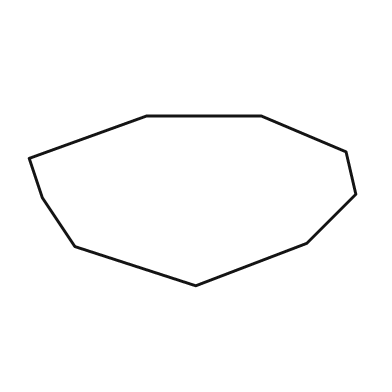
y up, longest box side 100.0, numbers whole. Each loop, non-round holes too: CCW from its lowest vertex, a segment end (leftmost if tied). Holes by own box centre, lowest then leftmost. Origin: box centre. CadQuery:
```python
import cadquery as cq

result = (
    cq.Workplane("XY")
    .moveTo(1.0, -26.0)
    .lineTo(35.0, -13.0)
    .lineTo(50.0, 2.0)
    .lineTo(47.0, 15.0)
    .lineTo(21.0, 26.0)
    .lineTo(-14.0, 26.0)
    .lineTo(-50.0, 13.0)
    .lineTo(-46.0, 1.0)
    .lineTo(-36.0, -14.0)
    .close()
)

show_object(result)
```